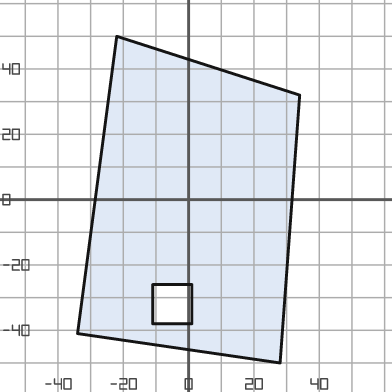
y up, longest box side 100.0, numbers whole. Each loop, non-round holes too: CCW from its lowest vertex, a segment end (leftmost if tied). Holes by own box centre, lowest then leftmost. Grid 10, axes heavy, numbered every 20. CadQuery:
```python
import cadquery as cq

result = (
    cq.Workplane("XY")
    .moveTo(28.0, -50.0)
    .lineTo(34.0, 32.0)
    .lineTo(-22.0, 50.0)
    .lineTo(-34.0, -41.0)
    .close()
    .moveTo(-11.0, -38.0)
    .lineTo(1.0, -38.0)
    .lineTo(1.0, -26.0)
    .lineTo(-11.0, -26.0)
    .close()
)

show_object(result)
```